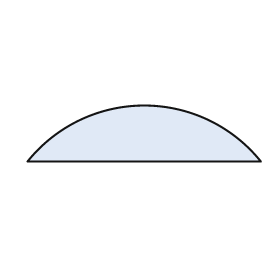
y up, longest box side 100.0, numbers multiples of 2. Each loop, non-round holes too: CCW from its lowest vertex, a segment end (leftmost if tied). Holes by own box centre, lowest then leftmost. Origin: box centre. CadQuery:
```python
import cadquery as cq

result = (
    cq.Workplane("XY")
    .moveTo(-50.0, -12.0)
    .lineTo(50.0, -12.0)
    .threePointArc((0.0, 12.0), (-50.0, -12.0))
    .close()
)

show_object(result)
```